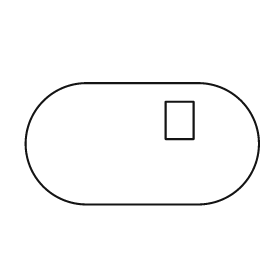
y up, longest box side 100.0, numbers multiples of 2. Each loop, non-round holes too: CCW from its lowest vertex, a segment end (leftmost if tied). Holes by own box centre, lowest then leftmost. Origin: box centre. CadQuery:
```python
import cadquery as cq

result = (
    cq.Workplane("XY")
    .moveTo(-24.0, -26.0)
    .lineTo(24.0, -26.0)
    .threePointArc((50.0, 0.0), (24.0, 26.0))
    .lineTo(-24.0, 26.0)
    .threePointArc((-50.0, 0.0), (-24.0, -26.0))
    .close()
    .moveTo(10.0, 2.0)
    .lineTo(22.0, 2.0)
    .lineTo(22.0, 18.0)
    .lineTo(10.0, 18.0)
    .close()
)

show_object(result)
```